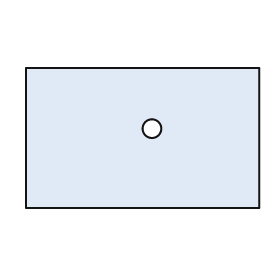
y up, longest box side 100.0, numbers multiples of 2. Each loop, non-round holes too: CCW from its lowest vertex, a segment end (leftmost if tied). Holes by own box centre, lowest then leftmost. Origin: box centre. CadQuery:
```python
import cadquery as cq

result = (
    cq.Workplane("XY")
    .moveTo(-50.0, -30.0)
    .lineTo(50.0, -30.0)
    .lineTo(50.0, 30.0)
    .lineTo(-50.0, 30.0)
    .close()
    .moveTo(4.0, 4.0)
    .circle(4.0)
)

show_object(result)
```